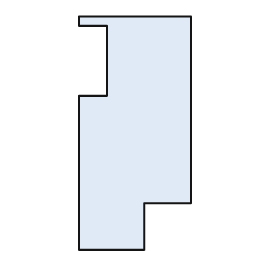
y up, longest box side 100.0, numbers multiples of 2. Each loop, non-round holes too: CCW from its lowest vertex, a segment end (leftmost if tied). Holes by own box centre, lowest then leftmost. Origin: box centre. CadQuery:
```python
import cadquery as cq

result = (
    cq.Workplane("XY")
    .moveTo(-24.0, -50.0)
    .lineTo(4.0, -50.0)
    .lineTo(4.0, -30.0)
    .lineTo(24.0, -30.0)
    .lineTo(24.0, 50.0)
    .lineTo(-24.0, 50.0)
    .lineTo(-24.0, 46.0)
    .lineTo(-12.0, 46.0)
    .lineTo(-12.0, 16.0)
    .lineTo(-24.0, 16.0)
    .close()
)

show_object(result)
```